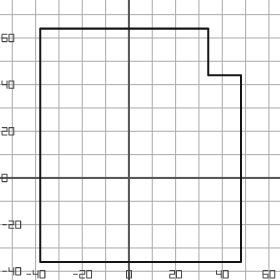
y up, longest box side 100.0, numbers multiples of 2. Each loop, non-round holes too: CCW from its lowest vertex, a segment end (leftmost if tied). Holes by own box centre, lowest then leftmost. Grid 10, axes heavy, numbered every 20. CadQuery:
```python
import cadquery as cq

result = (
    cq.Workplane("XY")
    .moveTo(-38.0, -36.0)
    .lineTo(48.0, -36.0)
    .lineTo(48.0, 44.0)
    .lineTo(34.0, 44.0)
    .lineTo(34.0, 64.0)
    .lineTo(-38.0, 64.0)
    .close()
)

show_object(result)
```